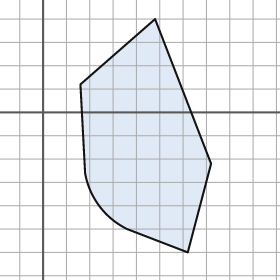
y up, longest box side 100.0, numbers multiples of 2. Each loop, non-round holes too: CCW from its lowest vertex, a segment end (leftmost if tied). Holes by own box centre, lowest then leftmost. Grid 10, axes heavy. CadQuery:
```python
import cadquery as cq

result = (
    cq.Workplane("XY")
    .moveTo(62.0, -60.0)
    .lineTo(72.0, -22.0)
    .lineTo(48.0, 40.0)
    .lineTo(16.0, 12.0)
    .lineTo(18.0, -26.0)
    .threePointArc((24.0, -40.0), (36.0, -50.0))
    .close()
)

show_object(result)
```